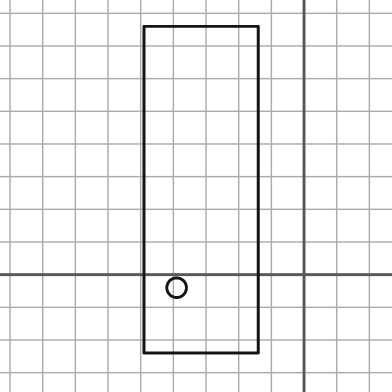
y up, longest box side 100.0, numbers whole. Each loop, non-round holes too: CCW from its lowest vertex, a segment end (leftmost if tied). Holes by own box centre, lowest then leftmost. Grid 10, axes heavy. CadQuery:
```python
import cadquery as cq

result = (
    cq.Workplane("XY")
    .moveTo(-49.0, -24.0)
    .lineTo(-14.0, -24.0)
    .lineTo(-14.0, 76.0)
    .lineTo(-49.0, 76.0)
    .close()
    .moveTo(-39.0, -4.0)
    .circle(3.0)
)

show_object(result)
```